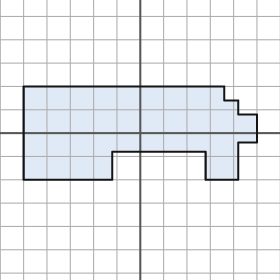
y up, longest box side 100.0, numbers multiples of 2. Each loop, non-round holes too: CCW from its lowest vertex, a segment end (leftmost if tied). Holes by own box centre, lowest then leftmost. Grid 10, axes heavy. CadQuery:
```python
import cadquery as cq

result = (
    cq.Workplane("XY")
    .moveTo(-50.0, -20.0)
    .lineTo(-12.0, -20.0)
    .lineTo(-12.0, -8.0)
    .lineTo(28.0, -8.0)
    .lineTo(28.0, -20.0)
    .lineTo(42.0, -20.0)
    .lineTo(42.0, -4.0)
    .lineTo(50.0, -4.0)
    .lineTo(50.0, 8.0)
    .lineTo(42.0, 8.0)
    .lineTo(42.0, 14.0)
    .lineTo(36.0, 14.0)
    .lineTo(36.0, 20.0)
    .lineTo(-50.0, 20.0)
    .close()
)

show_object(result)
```